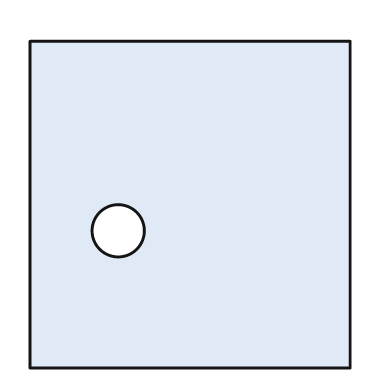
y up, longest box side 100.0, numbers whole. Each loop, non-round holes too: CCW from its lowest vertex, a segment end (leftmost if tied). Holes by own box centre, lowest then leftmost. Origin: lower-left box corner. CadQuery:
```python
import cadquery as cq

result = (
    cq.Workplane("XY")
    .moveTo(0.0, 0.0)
    .lineTo(98.0, 0.0)
    .lineTo(98.0, 100.0)
    .lineTo(0.0, 100.0)
    .close()
    .moveTo(27.0, 42.0)
    .circle(8.0)
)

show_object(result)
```